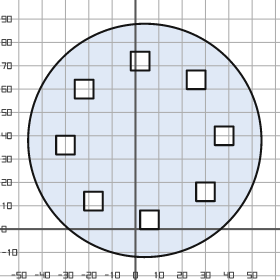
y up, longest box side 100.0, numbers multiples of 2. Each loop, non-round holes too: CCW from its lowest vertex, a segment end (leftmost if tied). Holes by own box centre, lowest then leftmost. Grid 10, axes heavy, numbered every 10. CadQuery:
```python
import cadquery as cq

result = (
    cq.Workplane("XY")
    .moveTo(4.0, 38.0)
    .circle(50.0)
    .moveTo(2.0, 0.0)
    .lineTo(10.0, 0.0)
    .lineTo(10.0, 8.0)
    .lineTo(2.0, 8.0)
    .close()
    .moveTo(-22.0, 8.0)
    .lineTo(-14.0, 8.0)
    .lineTo(-14.0, 16.0)
    .lineTo(-22.0, 16.0)
    .close()
    .moveTo(26.0, 12.0)
    .lineTo(34.0, 12.0)
    .lineTo(34.0, 20.0)
    .lineTo(26.0, 20.0)
    .close()
    .moveTo(-34.0, 32.0)
    .lineTo(-26.0, 32.0)
    .lineTo(-26.0, 40.0)
    .lineTo(-34.0, 40.0)
    .close()
    .moveTo(34.0, 36.0)
    .lineTo(42.0, 36.0)
    .lineTo(42.0, 44.0)
    .lineTo(34.0, 44.0)
    .close()
    .moveTo(-26.0, 56.0)
    .lineTo(-18.0, 56.0)
    .lineTo(-18.0, 64.0)
    .lineTo(-26.0, 64.0)
    .close()
    .moveTo(22.0, 60.0)
    .lineTo(30.0, 60.0)
    .lineTo(30.0, 68.0)
    .lineTo(22.0, 68.0)
    .close()
    .moveTo(-2.0, 68.0)
    .lineTo(6.0, 68.0)
    .lineTo(6.0, 76.0)
    .lineTo(-2.0, 76.0)
    .close()
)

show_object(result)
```